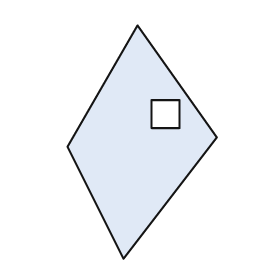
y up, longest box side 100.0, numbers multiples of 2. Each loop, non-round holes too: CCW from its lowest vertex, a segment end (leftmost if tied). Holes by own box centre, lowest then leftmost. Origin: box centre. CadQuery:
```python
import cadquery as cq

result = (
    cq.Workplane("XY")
    .moveTo(-8.0, -50.0)
    .lineTo(32.0, 2.0)
    .lineTo(-2.0, 50.0)
    .lineTo(-32.0, -2.0)
    .close()
    .moveTo(4.0, 6.0)
    .lineTo(16.0, 6.0)
    .lineTo(16.0, 18.0)
    .lineTo(4.0, 18.0)
    .close()
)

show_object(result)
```